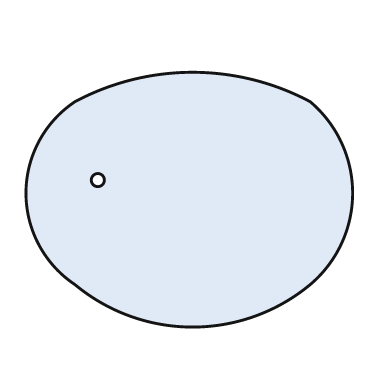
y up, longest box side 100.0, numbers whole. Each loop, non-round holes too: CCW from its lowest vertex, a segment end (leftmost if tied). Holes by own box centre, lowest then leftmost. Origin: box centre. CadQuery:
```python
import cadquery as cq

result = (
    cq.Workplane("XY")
    .moveTo(-35.0, -26.0)
    .threePointArc((1.0, -39.0), (37.0, -26.0))
    .threePointArc((50.0, 2.0), (37.0, 30.0))
    .threePointArc((1.0, 39.0), (-35.0, 30.0))
    .threePointArc((-50.0, 2.0), (-35.0, -26.0))
    .close()
    .moveTo(-28.0, 6.0)
    .circle(2.0)
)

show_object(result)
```